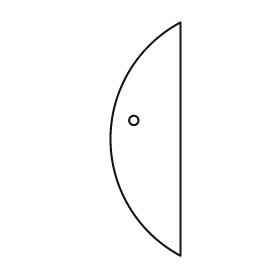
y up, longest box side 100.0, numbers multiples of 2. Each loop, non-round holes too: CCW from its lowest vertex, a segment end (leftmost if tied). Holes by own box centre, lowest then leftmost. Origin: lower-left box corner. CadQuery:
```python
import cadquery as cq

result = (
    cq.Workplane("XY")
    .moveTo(30.0, 0.0)
    .lineTo(30.0, 100.0)
    .threePointArc((0.0, 50.0), (30.0, 0.0))
    .close()
    .moveTo(10.0, 58.0)
    .circle(2.0)
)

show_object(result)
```